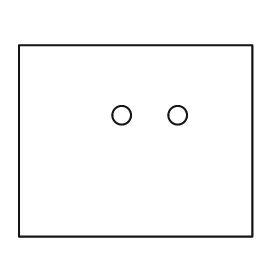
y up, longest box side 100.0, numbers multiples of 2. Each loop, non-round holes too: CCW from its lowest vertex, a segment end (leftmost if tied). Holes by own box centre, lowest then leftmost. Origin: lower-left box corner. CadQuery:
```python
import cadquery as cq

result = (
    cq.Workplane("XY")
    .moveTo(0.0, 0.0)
    .lineTo(100.0, 0.0)
    .lineTo(100.0, 82.0)
    .lineTo(0.0, 82.0)
    .close()
    .moveTo(44.0, 52.0)
    .circle(4.0)
    .moveTo(68.0, 52.0)
    .circle(4.0)
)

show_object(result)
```